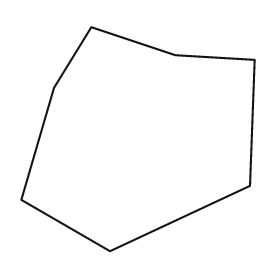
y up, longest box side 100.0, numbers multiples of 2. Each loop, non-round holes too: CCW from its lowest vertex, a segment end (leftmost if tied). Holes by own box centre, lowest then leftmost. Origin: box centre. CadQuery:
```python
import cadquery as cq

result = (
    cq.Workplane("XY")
    .moveTo(-12.0, -48.0)
    .lineTo(48.0, -20.0)
    .lineTo(50.0, 34.0)
    .lineTo(16.0, 36.0)
    .lineTo(-20.0, 48.0)
    .lineTo(-36.0, 22.0)
    .lineTo(-50.0, -26.0)
    .close()
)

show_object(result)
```